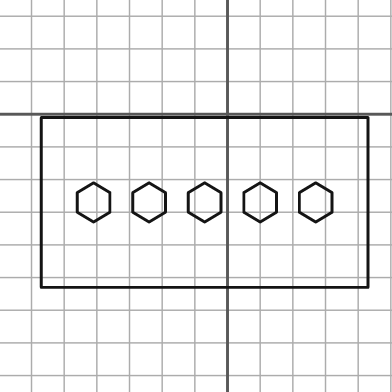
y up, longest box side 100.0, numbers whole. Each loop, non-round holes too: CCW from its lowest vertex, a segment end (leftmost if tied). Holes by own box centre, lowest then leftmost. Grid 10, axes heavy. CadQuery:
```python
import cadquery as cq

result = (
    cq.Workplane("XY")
    .moveTo(-57.0, -53.0)
    .lineTo(43.0, -53.0)
    .lineTo(43.0, -1.0)
    .lineTo(-57.0, -1.0)
    .close()
    .moveTo(-41.0, -33.0)
    .lineTo(-36.0, -30.0)
    .lineTo(-36.0, -24.0)
    .lineTo(-41.0, -21.0)
    .lineTo(-46.0, -24.0)
    .lineTo(-46.0, -30.0)
    .close()
    .moveTo(-24.0, -33.0)
    .lineTo(-19.0, -30.0)
    .lineTo(-19.0, -24.0)
    .lineTo(-24.0, -21.0)
    .lineTo(-29.0, -24.0)
    .lineTo(-29.0, -30.0)
    .close()
    .moveTo(-7.0, -33.0)
    .lineTo(-2.0, -30.0)
    .lineTo(-2.0, -24.0)
    .lineTo(-7.0, -21.0)
    .lineTo(-12.0, -24.0)
    .lineTo(-12.0, -30.0)
    .close()
    .moveTo(10.0, -33.0)
    .lineTo(15.0, -30.0)
    .lineTo(15.0, -24.0)
    .lineTo(10.0, -21.0)
    .lineTo(5.0, -24.0)
    .lineTo(5.0, -30.0)
    .close()
    .moveTo(27.0, -33.0)
    .lineTo(32.0, -30.0)
    .lineTo(32.0, -24.0)
    .lineTo(27.0, -21.0)
    .lineTo(22.0, -24.0)
    .lineTo(22.0, -30.0)
    .close()
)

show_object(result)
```